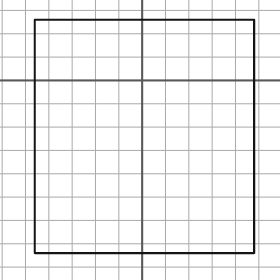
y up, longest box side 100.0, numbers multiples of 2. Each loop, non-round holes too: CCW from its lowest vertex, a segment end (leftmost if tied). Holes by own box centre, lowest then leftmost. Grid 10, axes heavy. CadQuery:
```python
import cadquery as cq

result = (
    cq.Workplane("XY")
    .moveTo(-46.0, -74.0)
    .lineTo(48.0, -74.0)
    .lineTo(48.0, 26.0)
    .lineTo(-46.0, 26.0)
    .close()
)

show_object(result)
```